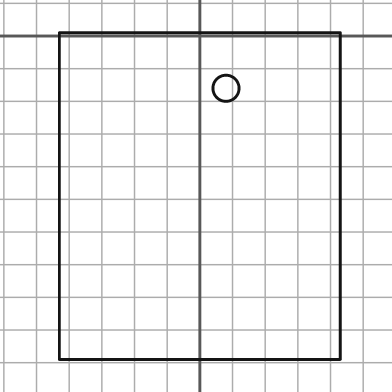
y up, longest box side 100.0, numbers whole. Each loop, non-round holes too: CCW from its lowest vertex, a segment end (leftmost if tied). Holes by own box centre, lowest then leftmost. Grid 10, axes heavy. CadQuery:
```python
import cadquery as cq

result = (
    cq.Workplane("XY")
    .moveTo(-43.0, -99.0)
    .lineTo(43.0, -99.0)
    .lineTo(43.0, 1.0)
    .lineTo(-43.0, 1.0)
    .close()
    .moveTo(8.0, -16.0)
    .circle(4.0)
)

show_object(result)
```